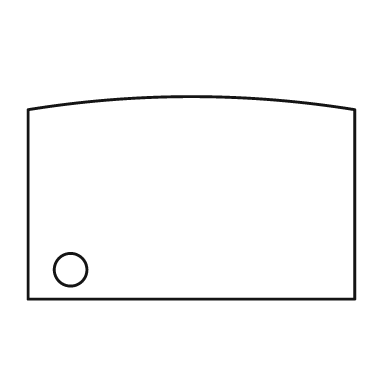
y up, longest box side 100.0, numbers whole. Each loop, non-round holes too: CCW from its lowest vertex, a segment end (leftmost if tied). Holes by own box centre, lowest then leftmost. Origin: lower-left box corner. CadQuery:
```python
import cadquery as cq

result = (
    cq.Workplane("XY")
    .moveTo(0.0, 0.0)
    .lineTo(100.0, 0.0)
    .lineTo(100.0, 58.0)
    .threePointArc((50.0, 62.0), (0.0, 58.0))
    .close()
    .moveTo(13.0, 9.0)
    .circle(5.0)
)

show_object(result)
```